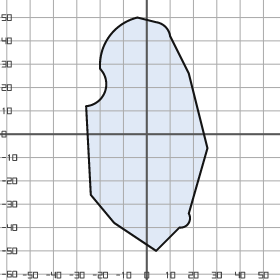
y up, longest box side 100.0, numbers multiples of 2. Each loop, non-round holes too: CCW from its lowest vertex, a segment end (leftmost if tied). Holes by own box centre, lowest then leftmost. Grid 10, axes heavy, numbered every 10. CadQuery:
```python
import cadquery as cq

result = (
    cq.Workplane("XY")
    .moveTo(4.0, -50.0)
    .lineTo(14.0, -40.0)
    .threePointArc((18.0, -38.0), (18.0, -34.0))
    .lineTo(26.0, -6.0)
    .lineTo(18.0, 26.0)
    .lineTo(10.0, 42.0)
    .threePointArc((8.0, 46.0), (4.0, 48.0))
    .lineTo(-4.0, 50.0)
    .threePointArc((-16.0, 42.0), (-20.0, 28.0))
    .threePointArc((-18.0, 18.0), (-26.0, 12.0))
    .lineTo(-24.0, -26.0)
    .lineTo(-14.0, -38.0)
    .close()
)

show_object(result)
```